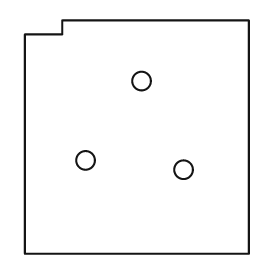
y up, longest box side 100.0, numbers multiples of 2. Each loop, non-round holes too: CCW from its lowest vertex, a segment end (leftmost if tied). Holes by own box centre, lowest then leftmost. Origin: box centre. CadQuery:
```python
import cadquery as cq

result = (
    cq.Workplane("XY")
    .moveTo(-48.0, -50.0)
    .lineTo(48.0, -50.0)
    .lineTo(48.0, 50.0)
    .lineTo(-32.0, 50.0)
    .lineTo(-32.0, 44.0)
    .lineTo(-48.0, 44.0)
    .close()
    .moveTo(20.0, -14.0)
    .circle(4.0)
    .moveTo(-22.0, -10.0)
    .circle(4.0)
    .moveTo(2.0, 24.0)
    .circle(4.0)
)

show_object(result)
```